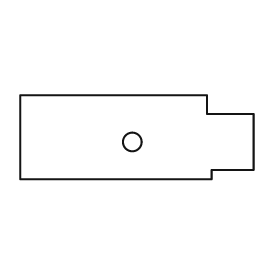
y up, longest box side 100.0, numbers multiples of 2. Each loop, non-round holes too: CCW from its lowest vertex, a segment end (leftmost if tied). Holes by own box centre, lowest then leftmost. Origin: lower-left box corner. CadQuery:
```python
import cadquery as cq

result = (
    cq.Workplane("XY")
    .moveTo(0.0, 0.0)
    .lineTo(82.0, 0.0)
    .lineTo(82.0, 4.0)
    .lineTo(100.0, 4.0)
    .lineTo(100.0, 28.0)
    .lineTo(80.0, 28.0)
    .lineTo(80.0, 36.0)
    .lineTo(0.0, 36.0)
    .close()
    .moveTo(48.0, 16.0)
    .circle(4.0)
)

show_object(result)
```